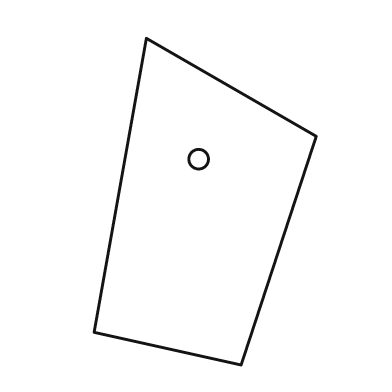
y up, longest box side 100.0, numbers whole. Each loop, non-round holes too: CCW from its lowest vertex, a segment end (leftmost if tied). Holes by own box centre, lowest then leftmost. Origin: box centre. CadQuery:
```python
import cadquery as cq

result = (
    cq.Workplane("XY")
    .moveTo(11.0, -50.0)
    .lineTo(34.0, 20.0)
    .lineTo(-18.0, 50.0)
    .lineTo(-34.0, -40.0)
    .close()
    .moveTo(-2.0, 13.0)
    .circle(3.0)
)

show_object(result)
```